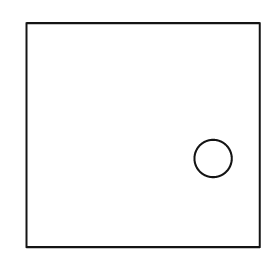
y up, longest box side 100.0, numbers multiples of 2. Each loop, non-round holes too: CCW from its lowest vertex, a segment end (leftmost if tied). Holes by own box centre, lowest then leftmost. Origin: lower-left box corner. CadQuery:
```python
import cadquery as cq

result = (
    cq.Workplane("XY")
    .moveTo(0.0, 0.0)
    .lineTo(100.0, 0.0)
    .lineTo(100.0, 96.0)
    .lineTo(0.0, 96.0)
    .close()
    .moveTo(80.0, 38.0)
    .circle(8.0)
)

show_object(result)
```